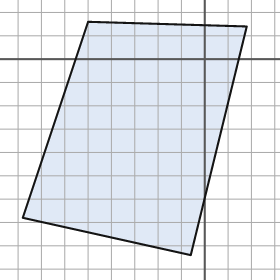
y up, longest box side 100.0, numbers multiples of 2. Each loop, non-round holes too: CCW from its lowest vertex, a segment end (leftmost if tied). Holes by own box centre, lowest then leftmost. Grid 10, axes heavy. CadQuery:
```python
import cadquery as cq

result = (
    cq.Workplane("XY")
    .moveTo(-6.0, -84.0)
    .lineTo(18.0, 14.0)
    .lineTo(-50.0, 16.0)
    .lineTo(-78.0, -68.0)
    .close()
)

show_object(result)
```